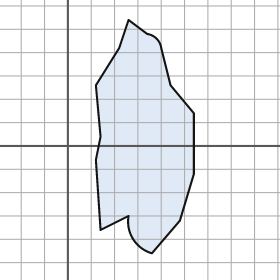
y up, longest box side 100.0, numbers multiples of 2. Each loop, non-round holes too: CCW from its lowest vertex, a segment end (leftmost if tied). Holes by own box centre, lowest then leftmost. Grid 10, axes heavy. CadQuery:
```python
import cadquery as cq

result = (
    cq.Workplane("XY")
    .moveTo(36.0, -46.0)
    .lineTo(48.0, -32.0)
    .lineTo(54.0, -12.0)
    .lineTo(54.0, 14.0)
    .lineTo(44.0, 26.0)
    .lineTo(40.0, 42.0)
    .threePointArc((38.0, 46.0), (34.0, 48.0))
    .lineTo(26.0, 54.0)
    .lineTo(22.0, 42.0)
    .lineTo(12.0, 26.0)
    .lineTo(14.0, 4.0)
    .lineTo(12.0, -6.0)
    .lineTo(14.0, -36.0)
    .lineTo(26.0, -30.0)
    .threePointArc((28.0, -40.0), (36.0, -46.0))
    .close()
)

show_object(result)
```